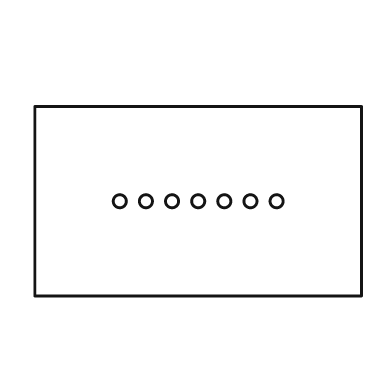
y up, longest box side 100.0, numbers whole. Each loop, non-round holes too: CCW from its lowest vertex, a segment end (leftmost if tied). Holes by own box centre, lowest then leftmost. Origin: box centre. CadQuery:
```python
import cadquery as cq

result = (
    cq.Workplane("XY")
    .moveTo(-50.0, -29.0)
    .lineTo(50.0, -29.0)
    .lineTo(50.0, 29.0)
    .lineTo(-50.0, 29.0)
    .close()
    .moveTo(-24.0, 0.0)
    .circle(2.0)
    .moveTo(-16.0, 0.0)
    .circle(2.0)
    .moveTo(-8.0, 0.0)
    .circle(2.0)
    .moveTo(0.0, 0.0)
    .circle(2.0)
    .moveTo(8.0, 0.0)
    .circle(2.0)
    .moveTo(16.0, 0.0)
    .circle(2.0)
    .moveTo(24.0, 0.0)
    .circle(2.0)
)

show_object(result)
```